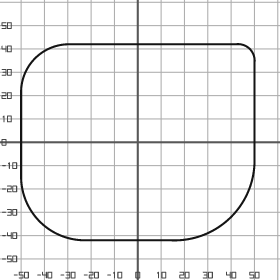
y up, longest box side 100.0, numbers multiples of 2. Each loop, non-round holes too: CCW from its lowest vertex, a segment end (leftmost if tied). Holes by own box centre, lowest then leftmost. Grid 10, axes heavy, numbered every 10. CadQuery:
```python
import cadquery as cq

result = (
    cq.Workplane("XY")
    .moveTo(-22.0, -42.0)
    .lineTo(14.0, -42.0)
    .threePointArc((40.0, -32.0), (50.0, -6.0))
    .lineTo(50.0, 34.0)
    .threePointArc((48.0, 40.0), (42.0, 42.0))
    .lineTo(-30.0, 42.0)
    .threePointArc((-44.0, 36.0), (-50.0, 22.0))
    .lineTo(-50.0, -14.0)
    .threePointArc((-42.0, -34.0), (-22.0, -42.0))
    .close()
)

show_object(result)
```